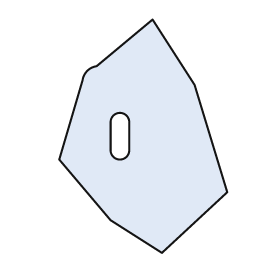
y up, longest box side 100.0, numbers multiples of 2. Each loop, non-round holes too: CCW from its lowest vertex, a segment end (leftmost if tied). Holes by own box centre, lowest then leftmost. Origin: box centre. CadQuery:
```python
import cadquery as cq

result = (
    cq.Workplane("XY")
    .moveTo(8.0, -50.0)
    .lineTo(36.0, -24.0)
    .lineTo(22.0, 22.0)
    .lineTo(4.0, 50.0)
    .lineTo(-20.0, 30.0)
    .threePointArc((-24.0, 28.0), (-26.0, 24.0))
    .lineTo(-36.0, -10.0)
    .lineTo(-14.0, -36.0)
    .close()
    .moveTo(-14.0, -6.0)
    .threePointArc((-10.0, -10.0), (-6.0, -6.0))
    .lineTo(-6.0, 6.0)
    .threePointArc((-10.0, 10.0), (-14.0, 6.0))
    .close()
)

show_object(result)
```